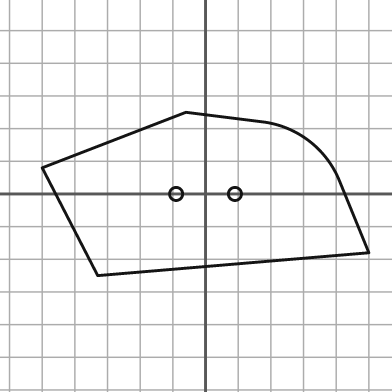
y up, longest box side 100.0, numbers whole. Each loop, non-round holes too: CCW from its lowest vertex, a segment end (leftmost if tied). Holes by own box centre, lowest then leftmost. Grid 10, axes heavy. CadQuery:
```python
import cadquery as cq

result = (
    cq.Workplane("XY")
    .moveTo(-33.0, -25.0)
    .lineTo(50.0, -18.0)
    .lineTo(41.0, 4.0)
    .threePointArc((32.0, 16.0), (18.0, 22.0))
    .lineTo(-6.0, 25.0)
    .lineTo(-50.0, 8.0)
    .close()
    .moveTo(-9.0, 0.0)
    .circle(2.0)
    .moveTo(9.0, 0.0)
    .circle(2.0)
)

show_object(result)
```